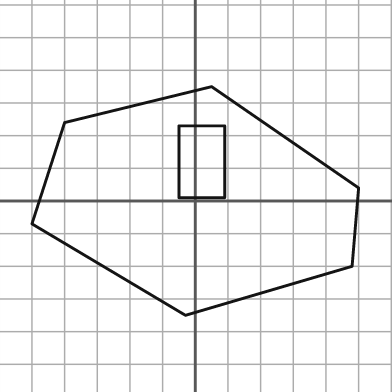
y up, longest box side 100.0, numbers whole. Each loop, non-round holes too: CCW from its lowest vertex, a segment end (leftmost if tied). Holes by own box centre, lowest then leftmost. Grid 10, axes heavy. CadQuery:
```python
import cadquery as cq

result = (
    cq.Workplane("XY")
    .moveTo(-3.0, -35.0)
    .lineTo(48.0, -20.0)
    .lineTo(50.0, 4.0)
    .lineTo(5.0, 35.0)
    .lineTo(-40.0, 24.0)
    .lineTo(-50.0, -7.0)
    .close()
    .moveTo(-5.0, 1.0)
    .lineTo(9.0, 1.0)
    .lineTo(9.0, 23.0)
    .lineTo(-5.0, 23.0)
    .close()
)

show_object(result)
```